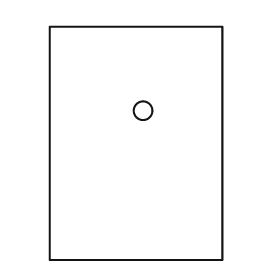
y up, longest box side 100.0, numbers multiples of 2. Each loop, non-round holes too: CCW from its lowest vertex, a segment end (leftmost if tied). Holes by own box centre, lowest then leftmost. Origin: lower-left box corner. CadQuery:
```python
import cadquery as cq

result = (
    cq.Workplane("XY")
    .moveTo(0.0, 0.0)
    .lineTo(74.0, 0.0)
    .lineTo(74.0, 100.0)
    .lineTo(0.0, 100.0)
    .close()
    .moveTo(40.0, 64.0)
    .circle(4.0)
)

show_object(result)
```